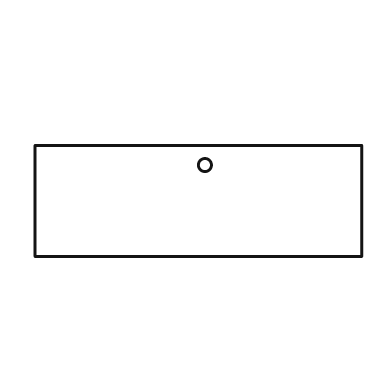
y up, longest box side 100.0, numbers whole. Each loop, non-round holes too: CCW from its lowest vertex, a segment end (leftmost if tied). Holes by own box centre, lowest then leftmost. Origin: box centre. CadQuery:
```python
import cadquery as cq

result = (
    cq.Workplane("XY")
    .moveTo(-50.0, -17.0)
    .lineTo(50.0, -17.0)
    .lineTo(50.0, 17.0)
    .lineTo(-50.0, 17.0)
    .close()
    .moveTo(2.0, 11.0)
    .circle(2.0)
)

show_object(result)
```